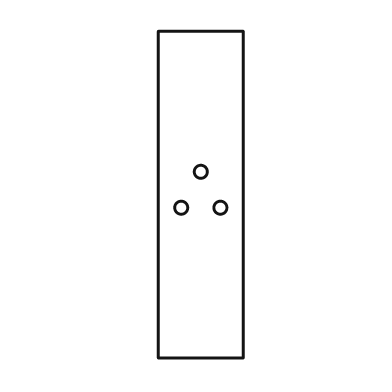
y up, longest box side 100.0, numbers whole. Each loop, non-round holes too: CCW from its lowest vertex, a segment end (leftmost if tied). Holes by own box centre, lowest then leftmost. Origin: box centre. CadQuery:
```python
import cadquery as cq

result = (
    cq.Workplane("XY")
    .moveTo(-13.0, -50.0)
    .lineTo(13.0, -50.0)
    .lineTo(13.0, 50.0)
    .lineTo(-13.0, 50.0)
    .close()
    .moveTo(-6.0, -4.0)
    .circle(2.0)
    .moveTo(6.0, -4.0)
    .circle(2.0)
    .moveTo(0.0, 7.0)
    .circle(2.0)
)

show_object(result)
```